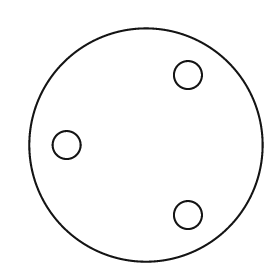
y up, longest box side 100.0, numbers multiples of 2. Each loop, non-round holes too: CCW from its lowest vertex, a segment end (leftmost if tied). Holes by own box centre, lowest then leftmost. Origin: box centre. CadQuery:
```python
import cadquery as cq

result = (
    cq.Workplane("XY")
    .moveTo(0.0, 0.0)
    .circle(50.0)
    .moveTo(18.0, -30.0)
    .circle(6.0)
    .moveTo(-34.0, 0.0)
    .circle(6.0)
    .moveTo(18.0, 30.0)
    .circle(6.0)
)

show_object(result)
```